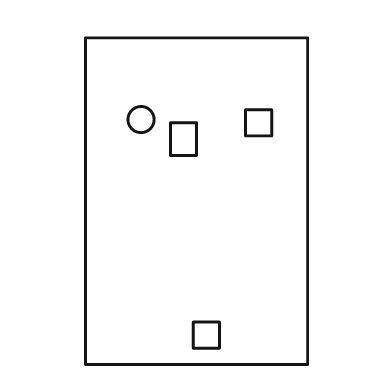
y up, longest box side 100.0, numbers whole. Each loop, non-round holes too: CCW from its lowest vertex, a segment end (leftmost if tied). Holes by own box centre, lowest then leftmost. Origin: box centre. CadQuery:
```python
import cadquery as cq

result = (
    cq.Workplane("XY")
    .moveTo(-34.0, -50.0)
    .lineTo(34.0, -50.0)
    .lineTo(34.0, 50.0)
    .lineTo(-34.0, 50.0)
    .close()
    .moveTo(-1.0, -45.0)
    .lineTo(7.0, -45.0)
    .lineTo(7.0, -37.0)
    .lineTo(-1.0, -37.0)
    .close()
    .moveTo(-8.0, 14.0)
    .lineTo(0.0, 14.0)
    .lineTo(0.0, 24.0)
    .lineTo(-8.0, 24.0)
    .close()
    .moveTo(15.0, 20.0)
    .lineTo(23.0, 20.0)
    .lineTo(23.0, 28.0)
    .lineTo(15.0, 28.0)
    .close()
    .moveTo(-17.0, 25.0)
    .circle(4.0)
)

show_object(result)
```